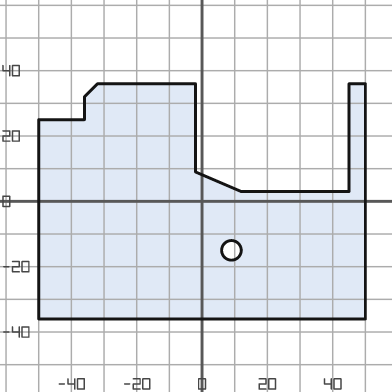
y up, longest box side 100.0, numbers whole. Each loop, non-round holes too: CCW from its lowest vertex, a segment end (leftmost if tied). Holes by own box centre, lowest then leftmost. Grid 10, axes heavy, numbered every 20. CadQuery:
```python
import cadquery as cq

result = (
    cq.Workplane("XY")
    .moveTo(-50.0, -36.0)
    .lineTo(50.0, -36.0)
    .lineTo(50.0, 36.0)
    .lineTo(45.0, 36.0)
    .lineTo(45.0, 3.0)
    .lineTo(12.0, 3.0)
    .lineTo(-2.0, 9.0)
    .lineTo(-2.0, 36.0)
    .lineTo(-32.0, 36.0)
    .lineTo(-36.0, 32.0)
    .lineTo(-36.0, 25.0)
    .lineTo(-50.0, 25.0)
    .close()
    .moveTo(9.0, -15.0)
    .circle(3.0)
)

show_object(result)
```